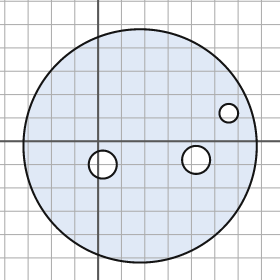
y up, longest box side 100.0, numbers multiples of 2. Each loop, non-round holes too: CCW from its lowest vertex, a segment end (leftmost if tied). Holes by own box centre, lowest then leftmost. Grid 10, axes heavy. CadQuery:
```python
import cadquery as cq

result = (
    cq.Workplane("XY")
    .moveTo(18.0, -2.0)
    .circle(50.0)
    .moveTo(2.0, -10.0)
    .circle(6.0)
    .moveTo(42.0, -8.0)
    .circle(6.0)
    .moveTo(56.0, 12.0)
    .circle(4.0)
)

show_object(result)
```